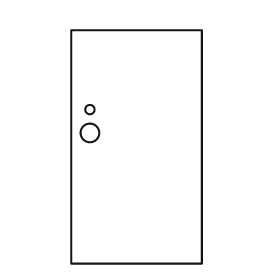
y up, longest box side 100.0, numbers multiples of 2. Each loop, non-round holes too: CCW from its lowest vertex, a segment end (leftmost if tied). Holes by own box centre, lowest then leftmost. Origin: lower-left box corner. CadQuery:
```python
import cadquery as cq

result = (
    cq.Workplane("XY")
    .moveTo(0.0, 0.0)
    .lineTo(56.0, 0.0)
    .lineTo(56.0, 100.0)
    .lineTo(0.0, 100.0)
    .close()
    .moveTo(8.0, 56.0)
    .circle(4.0)
    .moveTo(8.0, 66.0)
    .circle(2.0)
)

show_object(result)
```